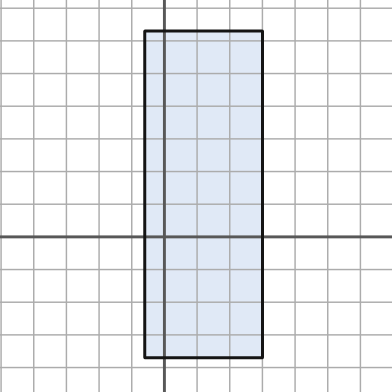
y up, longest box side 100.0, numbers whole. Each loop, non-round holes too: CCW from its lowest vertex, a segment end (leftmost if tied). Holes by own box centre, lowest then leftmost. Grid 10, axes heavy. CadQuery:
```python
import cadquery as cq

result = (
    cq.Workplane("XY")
    .moveTo(-6.0, -37.0)
    .lineTo(30.0, -37.0)
    .lineTo(30.0, 63.0)
    .lineTo(-6.0, 63.0)
    .close()
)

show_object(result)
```